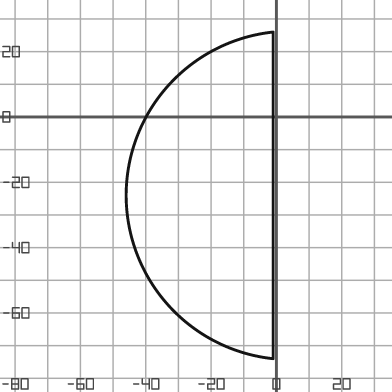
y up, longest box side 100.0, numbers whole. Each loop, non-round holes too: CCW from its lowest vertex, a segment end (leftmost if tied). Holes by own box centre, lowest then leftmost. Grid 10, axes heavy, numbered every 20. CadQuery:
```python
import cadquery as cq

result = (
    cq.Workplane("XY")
    .moveTo(-1.0, -74.0)
    .lineTo(-1.0, 26.0)
    .threePointArc((-46.0, -24.0), (-1.0, -74.0))
    .close()
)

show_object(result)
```